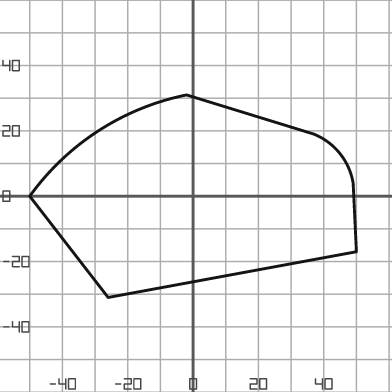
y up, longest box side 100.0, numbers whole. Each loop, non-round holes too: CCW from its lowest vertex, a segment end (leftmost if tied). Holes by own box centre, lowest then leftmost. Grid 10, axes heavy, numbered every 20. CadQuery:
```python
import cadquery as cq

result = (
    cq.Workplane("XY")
    .moveTo(-26.0, -31.0)
    .lineTo(50.0, -17.0)
    .lineTo(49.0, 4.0)
    .threePointArc((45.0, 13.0), (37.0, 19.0))
    .lineTo(-2.0, 31.0)
    .threePointArc((-29.0, 20.0), (-50.0, 0.0))
    .close()
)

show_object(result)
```